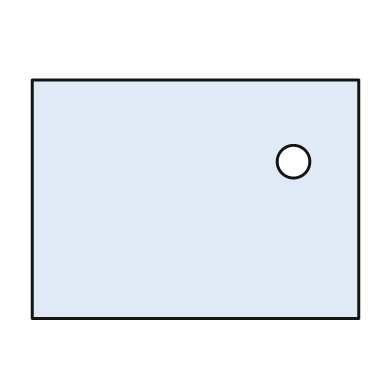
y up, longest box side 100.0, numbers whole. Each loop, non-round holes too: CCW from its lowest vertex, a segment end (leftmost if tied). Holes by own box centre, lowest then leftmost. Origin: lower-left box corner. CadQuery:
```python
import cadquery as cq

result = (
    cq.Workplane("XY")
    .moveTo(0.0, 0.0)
    .lineTo(100.0, 0.0)
    .lineTo(100.0, 73.0)
    .lineTo(0.0, 73.0)
    .close()
    .moveTo(80.0, 48.0)
    .circle(5.0)
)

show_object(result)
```